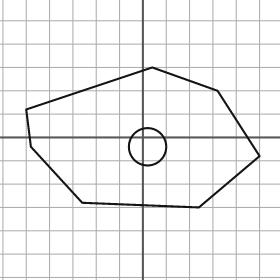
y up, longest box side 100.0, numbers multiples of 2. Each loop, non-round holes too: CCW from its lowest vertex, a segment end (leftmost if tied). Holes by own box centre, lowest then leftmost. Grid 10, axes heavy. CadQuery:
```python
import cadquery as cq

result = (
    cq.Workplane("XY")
    .moveTo(24.0, -30.0)
    .lineTo(50.0, -8.0)
    .lineTo(32.0, 20.0)
    .lineTo(4.0, 30.0)
    .lineTo(-50.0, 12.0)
    .lineTo(-48.0, -4.0)
    .lineTo(-26.0, -28.0)
    .close()
    .moveTo(2.0, -4.0)
    .circle(8.0)
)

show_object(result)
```